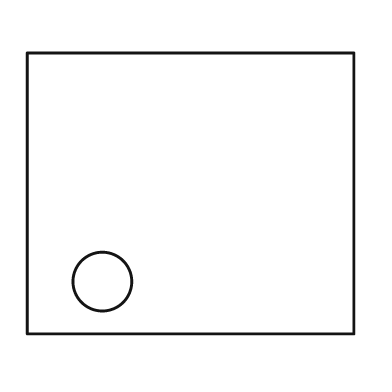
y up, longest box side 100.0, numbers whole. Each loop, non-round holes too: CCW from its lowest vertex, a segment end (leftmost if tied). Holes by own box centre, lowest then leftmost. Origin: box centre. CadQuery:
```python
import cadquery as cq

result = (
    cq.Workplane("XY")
    .moveTo(-50.0, -43.0)
    .lineTo(50.0, -43.0)
    .lineTo(50.0, 43.0)
    .lineTo(-50.0, 43.0)
    .close()
    .moveTo(-27.0, -27.0)
    .circle(9.0)
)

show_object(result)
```